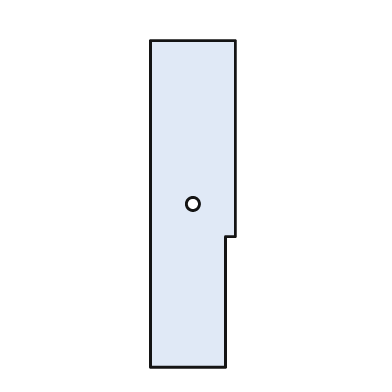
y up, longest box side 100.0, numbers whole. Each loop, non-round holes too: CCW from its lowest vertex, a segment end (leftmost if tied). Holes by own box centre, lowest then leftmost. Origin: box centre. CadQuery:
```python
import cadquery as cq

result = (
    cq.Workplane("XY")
    .moveTo(-13.0, -50.0)
    .lineTo(10.0, -50.0)
    .lineTo(10.0, -10.0)
    .lineTo(13.0, -10.0)
    .lineTo(13.0, 50.0)
    .lineTo(-13.0, 50.0)
    .close()
    .moveTo(0.0, 0.0)
    .circle(2.0)
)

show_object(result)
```